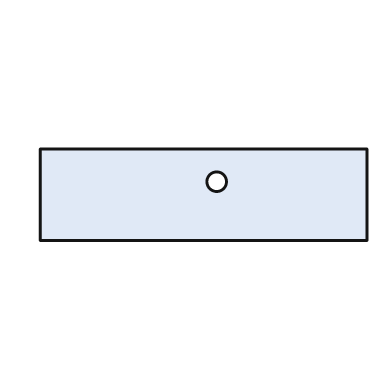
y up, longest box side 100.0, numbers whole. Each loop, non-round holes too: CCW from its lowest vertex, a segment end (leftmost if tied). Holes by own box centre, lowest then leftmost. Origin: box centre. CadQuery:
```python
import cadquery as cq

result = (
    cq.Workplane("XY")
    .moveTo(-50.0, -14.0)
    .lineTo(50.0, -14.0)
    .lineTo(50.0, 14.0)
    .lineTo(-50.0, 14.0)
    .close()
    .moveTo(4.0, 4.0)
    .circle(3.0)
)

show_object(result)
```